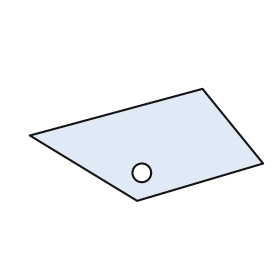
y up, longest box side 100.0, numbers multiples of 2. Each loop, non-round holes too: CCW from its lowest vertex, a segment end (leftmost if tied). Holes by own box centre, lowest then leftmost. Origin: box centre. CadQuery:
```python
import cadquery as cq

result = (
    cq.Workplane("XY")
    .moveTo(-4.0, -24.0)
    .lineTo(50.0, -8.0)
    .lineTo(24.0, 24.0)
    .lineTo(-50.0, 4.0)
    .close()
    .moveTo(-2.0, -12.0)
    .circle(4.0)
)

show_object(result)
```